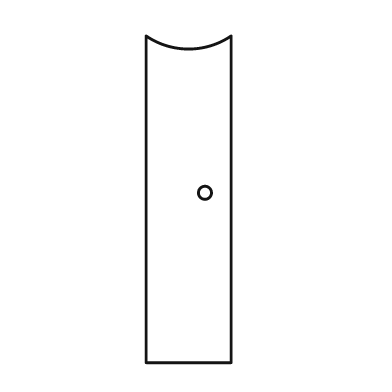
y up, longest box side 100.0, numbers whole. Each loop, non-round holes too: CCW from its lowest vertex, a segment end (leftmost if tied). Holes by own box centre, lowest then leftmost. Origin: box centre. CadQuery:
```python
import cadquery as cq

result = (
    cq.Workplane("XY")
    .moveTo(-13.0, -50.0)
    .lineTo(13.0, -50.0)
    .lineTo(13.0, 50.0)
    .threePointArc((0.0, 46.0), (-13.0, 50.0))
    .close()
    .moveTo(5.0, 2.0)
    .circle(2.0)
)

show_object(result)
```